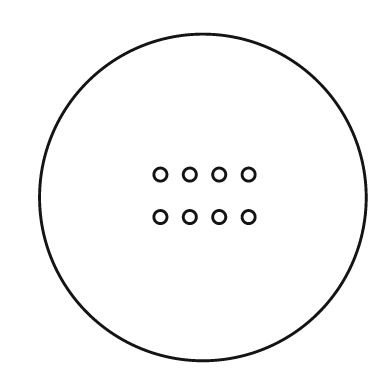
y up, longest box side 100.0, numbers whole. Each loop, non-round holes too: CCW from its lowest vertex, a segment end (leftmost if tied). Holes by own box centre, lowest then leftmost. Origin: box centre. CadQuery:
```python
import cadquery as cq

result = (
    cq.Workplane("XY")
    .moveTo(0.0, 0.0)
    .circle(50.0)
    .moveTo(-13.0, -6.0)
    .circle(2.0)
    .moveTo(-4.0, -6.0)
    .circle(2.0)
    .moveTo(5.0, -6.0)
    .circle(2.0)
    .moveTo(14.0, -6.0)
    .circle(2.0)
    .moveTo(-13.0, 7.0)
    .circle(2.0)
    .moveTo(-4.0, 7.0)
    .circle(2.0)
    .moveTo(5.0, 7.0)
    .circle(2.0)
    .moveTo(14.0, 7.0)
    .circle(2.0)
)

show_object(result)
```